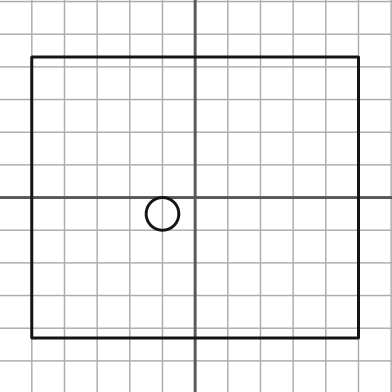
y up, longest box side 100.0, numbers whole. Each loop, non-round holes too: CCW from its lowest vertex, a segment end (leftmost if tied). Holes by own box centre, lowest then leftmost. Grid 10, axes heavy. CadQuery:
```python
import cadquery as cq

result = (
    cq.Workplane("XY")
    .moveTo(-50.0, -43.0)
    .lineTo(50.0, -43.0)
    .lineTo(50.0, 43.0)
    .lineTo(-50.0, 43.0)
    .close()
    .moveTo(-10.0, -5.0)
    .circle(5.0)
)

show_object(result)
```